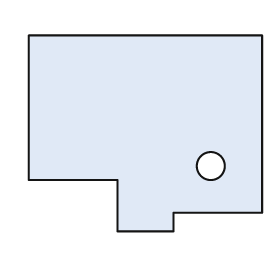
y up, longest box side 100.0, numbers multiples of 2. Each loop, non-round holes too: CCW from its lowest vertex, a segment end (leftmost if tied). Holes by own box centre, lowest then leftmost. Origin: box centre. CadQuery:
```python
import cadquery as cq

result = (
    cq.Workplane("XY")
    .moveTo(-12.0, -42.0)
    .lineTo(12.0, -42.0)
    .lineTo(12.0, -34.0)
    .lineTo(50.0, -34.0)
    .lineTo(50.0, 42.0)
    .lineTo(-50.0, 42.0)
    .lineTo(-50.0, -20.0)
    .lineTo(-12.0, -20.0)
    .close()
    .moveTo(28.0, -14.0)
    .circle(6.0)
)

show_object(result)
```